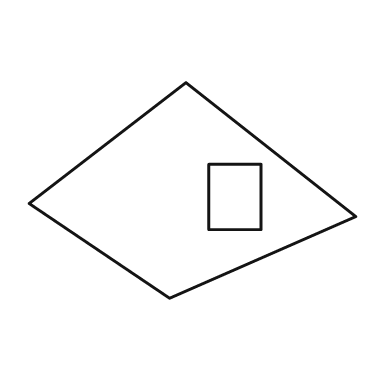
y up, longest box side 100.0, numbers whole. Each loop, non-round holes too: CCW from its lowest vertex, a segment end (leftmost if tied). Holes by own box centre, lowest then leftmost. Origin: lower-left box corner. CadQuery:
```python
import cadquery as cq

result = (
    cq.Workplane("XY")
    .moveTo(43.0, 0.0)
    .lineTo(100.0, 25.0)
    .lineTo(48.0, 66.0)
    .lineTo(0.0, 29.0)
    .close()
    .moveTo(55.0, 21.0)
    .lineTo(71.0, 21.0)
    .lineTo(71.0, 41.0)
    .lineTo(55.0, 41.0)
    .close()
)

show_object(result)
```